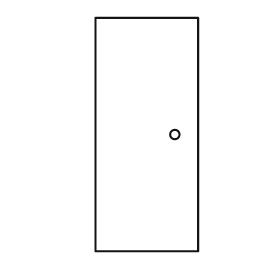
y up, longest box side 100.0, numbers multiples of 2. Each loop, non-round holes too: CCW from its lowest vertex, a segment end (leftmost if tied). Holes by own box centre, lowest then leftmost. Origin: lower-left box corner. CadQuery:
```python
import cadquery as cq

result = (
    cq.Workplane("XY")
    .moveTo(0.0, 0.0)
    .lineTo(44.0, 0.0)
    .lineTo(44.0, 100.0)
    .lineTo(0.0, 100.0)
    .close()
    .moveTo(34.0, 50.0)
    .circle(2.0)
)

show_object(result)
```